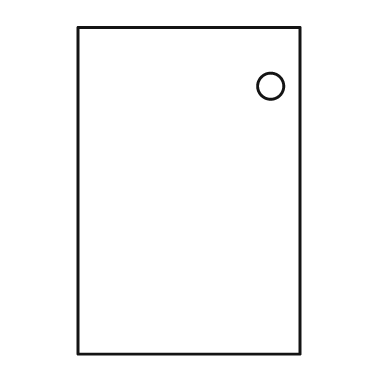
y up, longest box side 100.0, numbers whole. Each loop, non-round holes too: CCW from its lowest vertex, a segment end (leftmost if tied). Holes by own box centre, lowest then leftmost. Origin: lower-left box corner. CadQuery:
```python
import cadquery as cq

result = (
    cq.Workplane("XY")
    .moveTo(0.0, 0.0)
    .lineTo(68.0, 0.0)
    .lineTo(68.0, 100.0)
    .lineTo(0.0, 100.0)
    .close()
    .moveTo(59.0, 82.0)
    .circle(4.0)
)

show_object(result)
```